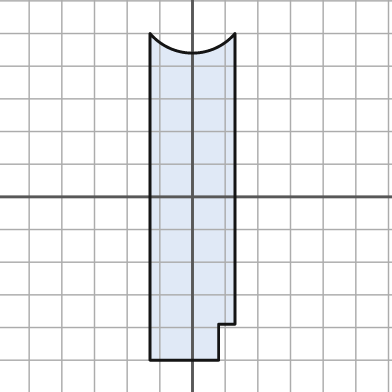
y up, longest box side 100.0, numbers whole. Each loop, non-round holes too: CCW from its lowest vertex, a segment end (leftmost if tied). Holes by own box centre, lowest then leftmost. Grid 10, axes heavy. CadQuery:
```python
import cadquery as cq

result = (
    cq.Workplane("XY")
    .moveTo(-13.0, -50.0)
    .lineTo(8.0, -50.0)
    .lineTo(8.0, -39.0)
    .lineTo(13.0, -39.0)
    .lineTo(13.0, 50.0)
    .threePointArc((0.0, 44.0), (-13.0, 50.0))
    .close()
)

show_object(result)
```